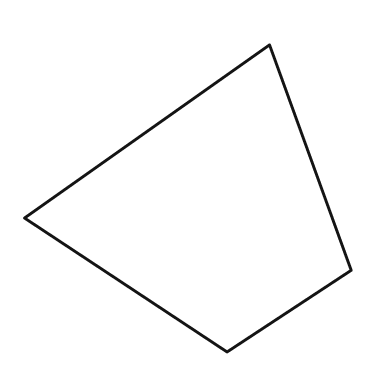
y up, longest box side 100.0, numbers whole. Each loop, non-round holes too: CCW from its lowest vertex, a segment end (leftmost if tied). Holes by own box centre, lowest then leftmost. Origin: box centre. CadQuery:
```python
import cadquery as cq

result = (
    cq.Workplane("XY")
    .moveTo(12.0, -47.0)
    .lineTo(50.0, -22.0)
    .lineTo(25.0, 47.0)
    .lineTo(-50.0, -6.0)
    .close()
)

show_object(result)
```